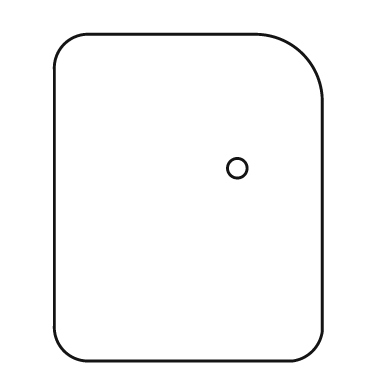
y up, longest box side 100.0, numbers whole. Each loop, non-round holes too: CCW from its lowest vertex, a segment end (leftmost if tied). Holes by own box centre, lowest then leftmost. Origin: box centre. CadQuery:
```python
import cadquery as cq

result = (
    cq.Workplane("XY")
    .moveTo(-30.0, -50.0)
    .lineTo(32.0, -50.0)
    .threePointArc((38.0, -47.0), (41.0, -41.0))
    .lineTo(41.0, 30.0)
    .threePointArc((35.0, 44.0), (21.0, 50.0))
    .lineTo(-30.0, 50.0)
    .threePointArc((-38.0, 47.0), (-41.0, 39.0))
    .lineTo(-41.0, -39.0)
    .threePointArc((-38.0, -47.0), (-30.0, -50.0))
    .close()
    .moveTo(15.0, 9.0)
    .circle(3.0)
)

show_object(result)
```